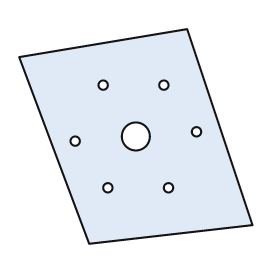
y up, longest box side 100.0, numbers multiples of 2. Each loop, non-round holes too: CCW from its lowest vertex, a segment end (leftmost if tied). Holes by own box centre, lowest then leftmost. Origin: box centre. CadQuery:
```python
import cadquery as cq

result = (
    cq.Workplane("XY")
    .moveTo(-20.0, -46.0)
    .lineTo(50.0, -38.0)
    .lineTo(22.0, 46.0)
    .lineTo(-50.0, 34.0)
    .close()
    .moveTo(-12.0, -22.0)
    .circle(2.0)
    .moveTo(14.0, -22.0)
    .circle(2.0)
    .moveTo(-26.0, -2.0)
    .circle(2.0)
    .moveTo(0.0, 0.0)
    .circle(6.0)
    .moveTo(26.0, 2.0)
    .circle(2.0)
    .moveTo(-14.0, 22.0)
    .circle(2.0)
    .moveTo(12.0, 22.0)
    .circle(2.0)
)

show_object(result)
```